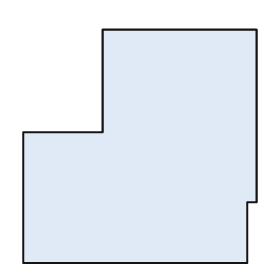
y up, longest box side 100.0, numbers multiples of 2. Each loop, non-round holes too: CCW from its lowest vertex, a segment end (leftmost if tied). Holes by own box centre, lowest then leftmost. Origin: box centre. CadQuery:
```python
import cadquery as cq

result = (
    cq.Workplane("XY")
    .moveTo(-50.0, -50.0)
    .lineTo(46.0, -50.0)
    .lineTo(46.0, -24.0)
    .lineTo(50.0, -24.0)
    .lineTo(50.0, 50.0)
    .lineTo(-16.0, 50.0)
    .lineTo(-16.0, 6.0)
    .lineTo(-50.0, 6.0)
    .close()
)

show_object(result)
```